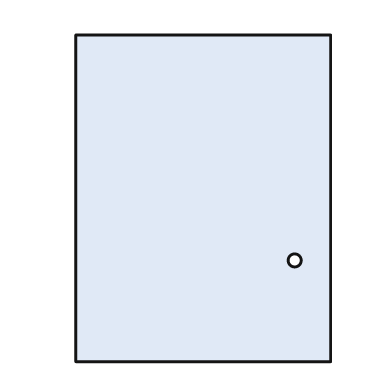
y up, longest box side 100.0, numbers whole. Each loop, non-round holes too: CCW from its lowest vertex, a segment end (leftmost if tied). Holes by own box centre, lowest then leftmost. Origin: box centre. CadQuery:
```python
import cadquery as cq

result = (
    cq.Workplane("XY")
    .moveTo(-39.0, -50.0)
    .lineTo(39.0, -50.0)
    .lineTo(39.0, 50.0)
    .lineTo(-39.0, 50.0)
    .close()
    .moveTo(28.0, -19.0)
    .circle(2.0)
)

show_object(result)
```